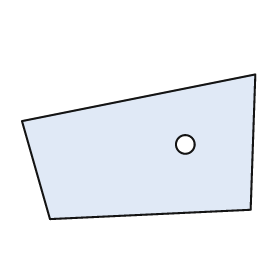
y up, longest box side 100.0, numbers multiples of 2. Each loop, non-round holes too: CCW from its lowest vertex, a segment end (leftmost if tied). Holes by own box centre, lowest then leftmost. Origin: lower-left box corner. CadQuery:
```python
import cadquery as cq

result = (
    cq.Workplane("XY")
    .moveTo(12.0, 0.0)
    .lineTo(98.0, 4.0)
    .lineTo(100.0, 62.0)
    .lineTo(0.0, 42.0)
    .close()
    .moveTo(70.0, 32.0)
    .circle(4.0)
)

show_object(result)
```